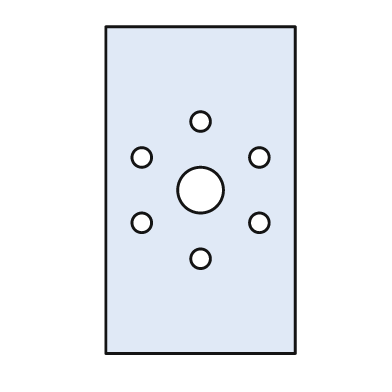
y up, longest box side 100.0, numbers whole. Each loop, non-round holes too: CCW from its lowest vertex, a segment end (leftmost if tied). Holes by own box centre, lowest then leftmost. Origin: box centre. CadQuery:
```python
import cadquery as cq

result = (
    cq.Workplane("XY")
    .moveTo(-29.0, -50.0)
    .lineTo(29.0, -50.0)
    .lineTo(29.0, 50.0)
    .lineTo(-29.0, 50.0)
    .close()
    .moveTo(0.0, -21.0)
    .circle(3.0)
    .moveTo(-18.0, -10.0)
    .circle(3.0)
    .moveTo(18.0, -10.0)
    .circle(3.0)
    .moveTo(0.0, 0.0)
    .circle(7.0)
    .moveTo(-18.0, 10.0)
    .circle(3.0)
    .moveTo(18.0, 10.0)
    .circle(3.0)
    .moveTo(0.0, 21.0)
    .circle(3.0)
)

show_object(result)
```